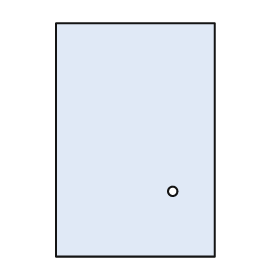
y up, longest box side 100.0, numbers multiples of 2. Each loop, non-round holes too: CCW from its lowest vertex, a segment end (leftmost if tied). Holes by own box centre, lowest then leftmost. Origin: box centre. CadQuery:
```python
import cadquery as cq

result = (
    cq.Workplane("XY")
    .moveTo(-34.0, -50.0)
    .lineTo(34.0, -50.0)
    .lineTo(34.0, 50.0)
    .lineTo(-34.0, 50.0)
    .close()
    .moveTo(16.0, -22.0)
    .circle(2.0)
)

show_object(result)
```